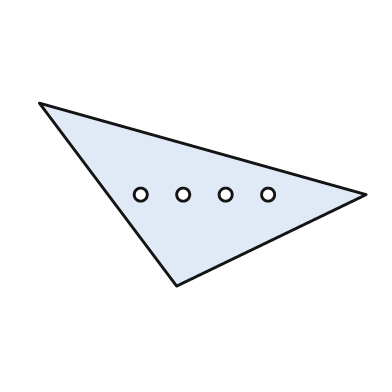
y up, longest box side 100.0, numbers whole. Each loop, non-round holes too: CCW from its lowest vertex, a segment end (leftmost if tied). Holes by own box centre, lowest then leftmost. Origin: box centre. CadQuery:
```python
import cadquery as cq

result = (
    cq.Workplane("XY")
    .moveTo(-8.0, -28.0)
    .lineTo(50.0, 0.0)
    .lineTo(-50.0, 28.0)
    .close()
    .moveTo(-19.0, 0.0)
    .circle(2.0)
    .moveTo(-6.0, 0.0)
    .circle(2.0)
    .moveTo(7.0, 0.0)
    .circle(2.0)
    .moveTo(20.0, 0.0)
    .circle(2.0)
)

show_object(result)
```